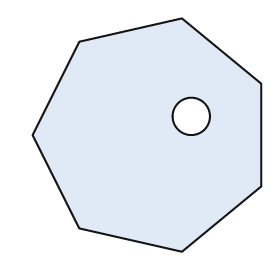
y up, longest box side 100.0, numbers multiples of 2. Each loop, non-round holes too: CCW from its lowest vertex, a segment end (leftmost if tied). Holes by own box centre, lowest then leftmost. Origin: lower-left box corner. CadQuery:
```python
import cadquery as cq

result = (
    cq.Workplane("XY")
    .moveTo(64.0, 0.0)
    .lineTo(98.0, 28.0)
    .lineTo(98.0, 72.0)
    .lineTo(64.0, 100.0)
    .lineTo(20.0, 90.0)
    .lineTo(0.0, 50.0)
    .lineTo(20.0, 10.0)
    .close()
    .moveTo(68.0, 58.0)
    .circle(8.0)
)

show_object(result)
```